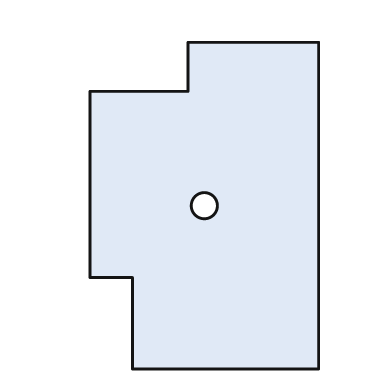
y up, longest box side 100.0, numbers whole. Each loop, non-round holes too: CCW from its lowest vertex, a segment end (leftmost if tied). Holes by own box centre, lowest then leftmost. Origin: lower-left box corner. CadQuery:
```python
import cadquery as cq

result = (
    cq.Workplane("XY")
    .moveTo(13.0, 0.0)
    .lineTo(70.0, 0.0)
    .lineTo(70.0, 100.0)
    .lineTo(30.0, 100.0)
    .lineTo(30.0, 85.0)
    .lineTo(0.0, 85.0)
    .lineTo(0.0, 28.0)
    .lineTo(13.0, 28.0)
    .close()
    .moveTo(35.0, 50.0)
    .circle(4.0)
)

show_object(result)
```